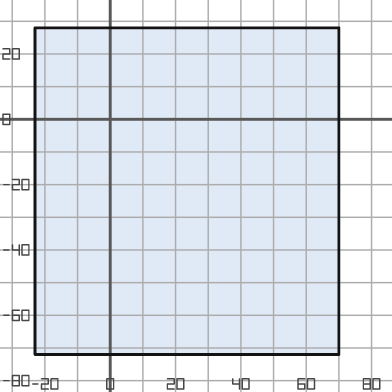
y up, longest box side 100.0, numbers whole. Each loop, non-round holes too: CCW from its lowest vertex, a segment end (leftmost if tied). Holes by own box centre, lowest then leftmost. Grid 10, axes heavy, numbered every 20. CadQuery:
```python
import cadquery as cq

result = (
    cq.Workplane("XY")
    .moveTo(-23.0, -72.0)
    .lineTo(70.0, -72.0)
    .lineTo(70.0, 28.0)
    .lineTo(-23.0, 28.0)
    .close()
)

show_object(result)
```